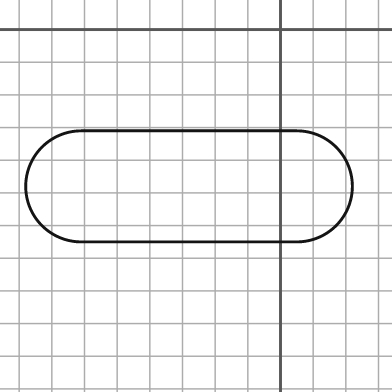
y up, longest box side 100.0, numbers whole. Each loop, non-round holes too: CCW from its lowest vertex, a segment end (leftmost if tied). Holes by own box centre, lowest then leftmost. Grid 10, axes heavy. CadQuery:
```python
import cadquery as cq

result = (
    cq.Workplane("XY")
    .moveTo(-61.0, -65.0)
    .lineTo(5.0, -65.0)
    .threePointArc((22.0, -48.0), (5.0, -31.0))
    .lineTo(-61.0, -31.0)
    .threePointArc((-78.0, -48.0), (-61.0, -65.0))
    .close()
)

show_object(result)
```